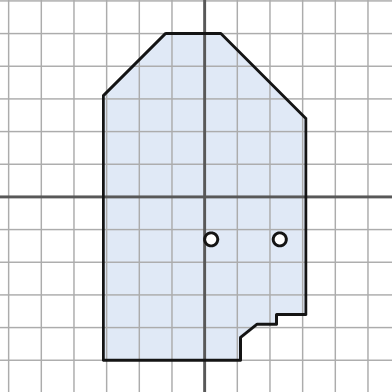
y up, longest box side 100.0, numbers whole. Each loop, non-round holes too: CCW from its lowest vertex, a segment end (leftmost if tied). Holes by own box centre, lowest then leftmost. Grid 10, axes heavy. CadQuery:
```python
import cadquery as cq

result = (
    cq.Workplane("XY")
    .moveTo(-31.0, -50.0)
    .lineTo(11.0, -50.0)
    .lineTo(11.0, -43.0)
    .lineTo(16.0, -39.0)
    .lineTo(22.0, -39.0)
    .lineTo(22.0, -36.0)
    .lineTo(31.0, -36.0)
    .lineTo(31.0, 24.0)
    .lineTo(5.0, 50.0)
    .lineTo(-12.0, 50.0)
    .lineTo(-31.0, 31.0)
    .close()
    .moveTo(2.0, -13.0)
    .circle(2.0)
    .moveTo(23.0, -13.0)
    .circle(2.0)
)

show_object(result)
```